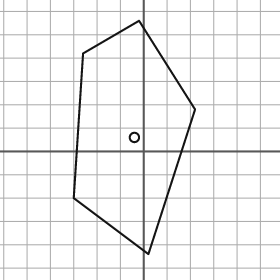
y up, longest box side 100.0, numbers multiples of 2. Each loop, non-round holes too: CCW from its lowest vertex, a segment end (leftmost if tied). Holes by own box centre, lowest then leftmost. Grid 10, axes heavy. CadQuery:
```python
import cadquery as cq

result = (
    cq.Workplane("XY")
    .moveTo(2.0, -44.0)
    .lineTo(22.0, 18.0)
    .lineTo(-2.0, 56.0)
    .lineTo(-26.0, 42.0)
    .lineTo(-30.0, -20.0)
    .close()
    .moveTo(-4.0, 6.0)
    .circle(2.0)
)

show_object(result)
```